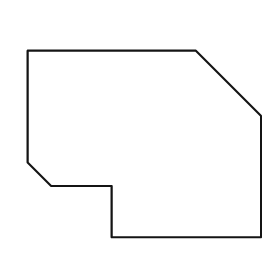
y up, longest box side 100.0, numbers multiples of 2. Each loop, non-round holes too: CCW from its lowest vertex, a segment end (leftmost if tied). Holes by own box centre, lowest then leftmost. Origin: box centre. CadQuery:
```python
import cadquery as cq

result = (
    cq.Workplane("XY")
    .moveTo(-14.0, -40.0)
    .lineTo(50.0, -40.0)
    .lineTo(50.0, 12.0)
    .lineTo(22.0, 40.0)
    .lineTo(-50.0, 40.0)
    .lineTo(-50.0, -8.0)
    .lineTo(-40.0, -18.0)
    .lineTo(-14.0, -18.0)
    .close()
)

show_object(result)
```